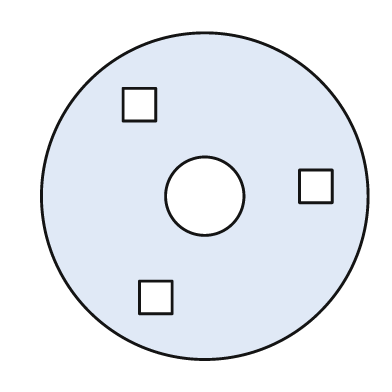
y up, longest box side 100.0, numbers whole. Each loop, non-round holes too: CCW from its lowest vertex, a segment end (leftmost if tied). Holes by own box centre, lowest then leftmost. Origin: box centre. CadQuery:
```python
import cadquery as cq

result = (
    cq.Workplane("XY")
    .moveTo(0.0, 0.0)
    .circle(50.0)
    .moveTo(-20.0, -36.0)
    .lineTo(-10.0, -36.0)
    .lineTo(-10.0, -26.0)
    .lineTo(-20.0, -26.0)
    .close()
    .moveTo(0.0, 0.0)
    .circle(12.0)
    .moveTo(29.0, -2.0)
    .lineTo(39.0, -2.0)
    .lineTo(39.0, 8.0)
    .lineTo(29.0, 8.0)
    .close()
    .moveTo(-25.0, 23.0)
    .lineTo(-15.0, 23.0)
    .lineTo(-15.0, 33.0)
    .lineTo(-25.0, 33.0)
    .close()
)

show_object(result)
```